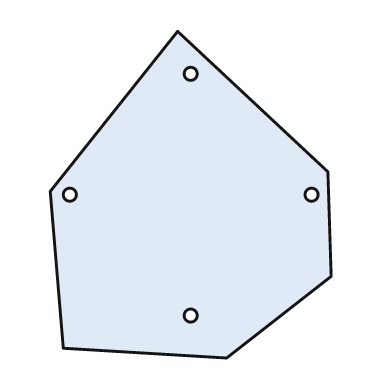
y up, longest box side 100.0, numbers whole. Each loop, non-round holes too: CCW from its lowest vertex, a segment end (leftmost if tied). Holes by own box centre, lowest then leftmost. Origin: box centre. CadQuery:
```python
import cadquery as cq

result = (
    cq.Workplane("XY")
    .moveTo(11.0, -50.0)
    .lineTo(43.0, -25.0)
    .lineTo(42.0, 7.0)
    .lineTo(-4.0, 50.0)
    .lineTo(-43.0, 1.0)
    .lineTo(-39.0, -47.0)
    .close()
    .moveTo(0.0, -37.0)
    .circle(2.0)
    .moveTo(-37.0, 0.0)
    .circle(2.0)
    .moveTo(37.0, 0.0)
    .circle(2.0)
    .moveTo(0.0, 37.0)
    .circle(2.0)
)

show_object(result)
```